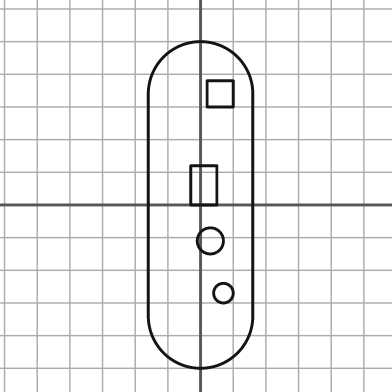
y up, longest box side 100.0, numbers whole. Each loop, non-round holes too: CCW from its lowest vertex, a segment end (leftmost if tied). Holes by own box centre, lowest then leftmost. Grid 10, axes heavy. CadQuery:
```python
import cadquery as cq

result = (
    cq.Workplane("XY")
    .moveTo(-16.0, -34.0)
    .threePointArc((0.0, -50.0), (16.0, -34.0))
    .lineTo(16.0, 34.0)
    .threePointArc((0.0, 50.0), (-16.0, 34.0))
    .close()
    .moveTo(7.0, -27.0)
    .circle(3.0)
    .moveTo(3.0, -11.0)
    .circle(4.0)
    .moveTo(-3.0, 0.0)
    .lineTo(5.0, 0.0)
    .lineTo(5.0, 12.0)
    .lineTo(-3.0, 12.0)
    .close()
    .moveTo(2.0, 30.0)
    .lineTo(10.0, 30.0)
    .lineTo(10.0, 38.0)
    .lineTo(2.0, 38.0)
    .close()
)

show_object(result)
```